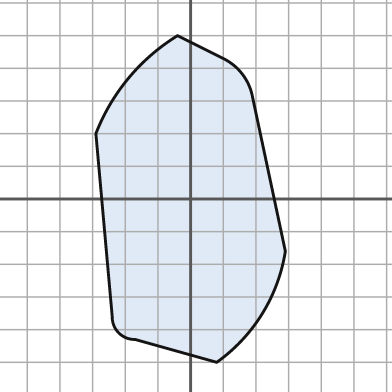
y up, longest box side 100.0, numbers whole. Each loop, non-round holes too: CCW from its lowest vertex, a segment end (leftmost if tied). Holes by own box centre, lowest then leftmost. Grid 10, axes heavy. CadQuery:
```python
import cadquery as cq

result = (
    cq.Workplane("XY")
    .moveTo(8.0, -50.0)
    .threePointArc((22.0, -35.0), (29.0, -16.0))
    .lineTo(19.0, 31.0)
    .threePointArc((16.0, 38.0), (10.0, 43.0))
    .lineTo(-4.0, 50.0)
    .threePointArc((-19.0, 37.0), (-29.0, 20.0))
    .lineTo(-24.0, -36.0)
    .threePointArc((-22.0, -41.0), (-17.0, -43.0))
    .close()
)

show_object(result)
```